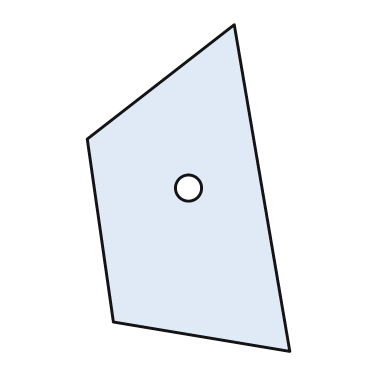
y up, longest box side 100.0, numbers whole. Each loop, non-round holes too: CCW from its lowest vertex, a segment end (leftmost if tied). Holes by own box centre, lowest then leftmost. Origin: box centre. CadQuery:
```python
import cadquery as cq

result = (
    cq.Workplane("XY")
    .moveTo(31.0, -50.0)
    .lineTo(14.0, 50.0)
    .lineTo(-31.0, 15.0)
    .lineTo(-23.0, -41.0)
    .close()
    .moveTo(0.0, 0.0)
    .circle(4.0)
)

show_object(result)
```